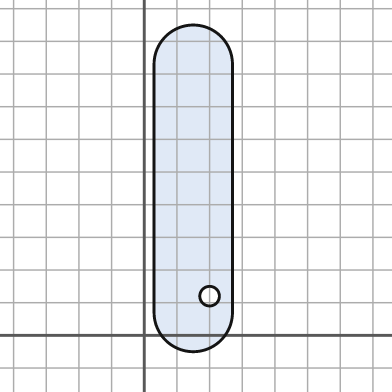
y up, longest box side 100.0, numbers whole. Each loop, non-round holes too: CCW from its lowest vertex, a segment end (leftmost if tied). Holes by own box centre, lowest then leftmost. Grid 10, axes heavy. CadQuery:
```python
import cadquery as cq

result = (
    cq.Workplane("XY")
    .moveTo(3.0, 7.0)
    .threePointArc((15.0, -5.0), (27.0, 7.0))
    .lineTo(27.0, 83.0)
    .threePointArc((15.0, 95.0), (3.0, 83.0))
    .close()
    .moveTo(20.0, 12.0)
    .circle(3.0)
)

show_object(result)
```